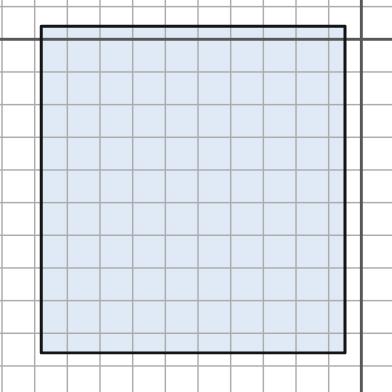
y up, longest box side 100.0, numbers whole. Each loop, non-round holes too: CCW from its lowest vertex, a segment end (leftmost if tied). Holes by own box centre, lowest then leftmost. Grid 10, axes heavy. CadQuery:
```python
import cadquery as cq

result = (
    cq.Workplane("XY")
    .moveTo(-98.0, -96.0)
    .lineTo(-5.0, -96.0)
    .lineTo(-5.0, 4.0)
    .lineTo(-98.0, 4.0)
    .close()
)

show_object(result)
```